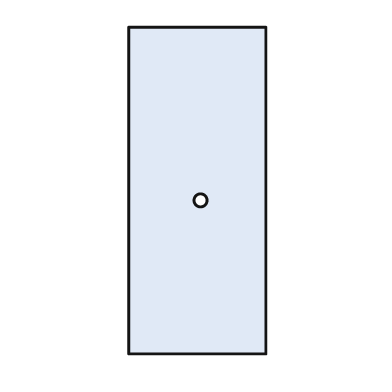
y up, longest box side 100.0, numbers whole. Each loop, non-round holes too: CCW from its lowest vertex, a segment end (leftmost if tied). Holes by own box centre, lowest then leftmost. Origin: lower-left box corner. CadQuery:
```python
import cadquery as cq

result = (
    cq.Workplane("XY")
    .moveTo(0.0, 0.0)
    .lineTo(42.0, 0.0)
    .lineTo(42.0, 100.0)
    .lineTo(0.0, 100.0)
    .close()
    .moveTo(22.0, 47.0)
    .circle(2.0)
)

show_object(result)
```